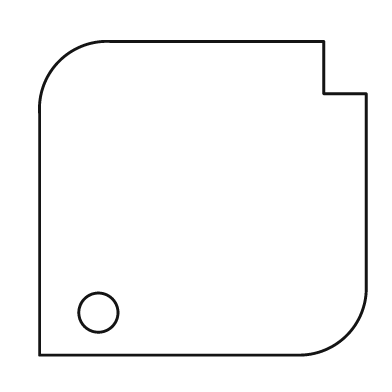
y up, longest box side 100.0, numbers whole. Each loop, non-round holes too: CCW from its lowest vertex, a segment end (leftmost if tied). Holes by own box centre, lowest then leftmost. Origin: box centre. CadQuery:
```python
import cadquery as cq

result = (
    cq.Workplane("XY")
    .moveTo(-50.0, -48.0)
    .lineTo(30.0, -48.0)
    .threePointArc((44.0, -42.0), (50.0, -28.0))
    .lineTo(50.0, 32.0)
    .lineTo(37.0, 32.0)
    .lineTo(37.0, 48.0)
    .lineTo(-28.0, 48.0)
    .threePointArc((-44.0, 42.0), (-50.0, 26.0))
    .close()
    .moveTo(-32.0, -35.0)
    .circle(6.0)
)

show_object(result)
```